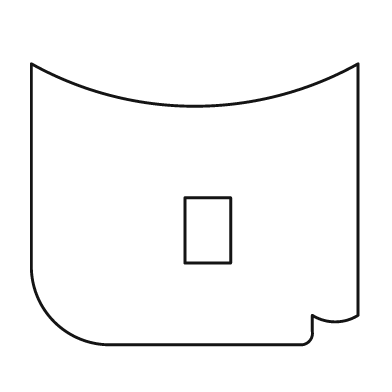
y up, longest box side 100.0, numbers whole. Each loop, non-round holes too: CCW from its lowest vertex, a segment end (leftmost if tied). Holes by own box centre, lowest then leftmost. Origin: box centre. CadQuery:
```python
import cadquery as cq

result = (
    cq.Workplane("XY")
    .moveTo(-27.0, -43.0)
    .lineTo(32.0, -43.0)
    .threePointArc((35.0, -42.0), (36.0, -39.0))
    .lineTo(36.0, -34.0)
    .threePointArc((43.0, -36.0), (50.0, -34.0))
    .lineTo(50.0, 43.0)
    .threePointArc((0.0, 30.0), (-50.0, 43.0))
    .lineTo(-50.0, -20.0)
    .threePointArc((-43.0, -36.0), (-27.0, -43.0))
    .close()
    .moveTo(-3.0, -18.0)
    .lineTo(11.0, -18.0)
    .lineTo(11.0, 2.0)
    .lineTo(-3.0, 2.0)
    .close()
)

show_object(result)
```